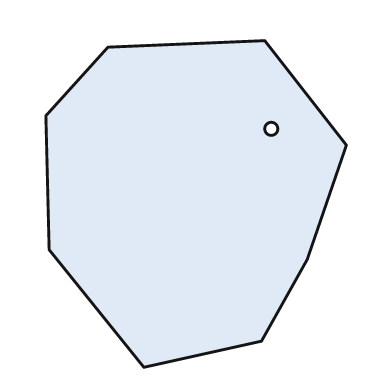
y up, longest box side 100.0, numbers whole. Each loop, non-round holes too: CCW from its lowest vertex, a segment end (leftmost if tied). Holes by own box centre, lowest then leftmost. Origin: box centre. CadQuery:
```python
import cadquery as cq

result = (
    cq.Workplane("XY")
    .moveTo(-16.0, -50.0)
    .lineTo(20.0, -42.0)
    .lineTo(34.0, -17.0)
    .lineTo(46.0, 18.0)
    .lineTo(21.0, 50.0)
    .lineTo(-27.0, 48.0)
    .lineTo(-46.0, 27.0)
    .lineTo(-45.0, -14.0)
    .close()
    .moveTo(23.0, 23.0)
    .circle(2.0)
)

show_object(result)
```